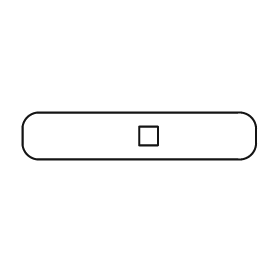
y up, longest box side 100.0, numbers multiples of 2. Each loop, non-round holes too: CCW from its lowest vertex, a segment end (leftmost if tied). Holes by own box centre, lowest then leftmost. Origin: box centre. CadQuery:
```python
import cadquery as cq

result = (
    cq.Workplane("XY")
    .moveTo(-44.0, -10.0)
    .lineTo(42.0, -10.0)
    .threePointArc((48.0, -8.0), (50.0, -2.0))
    .lineTo(50.0, 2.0)
    .threePointArc((48.0, 8.0), (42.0, 10.0))
    .lineTo(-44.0, 10.0)
    .threePointArc((-48.0, 8.0), (-50.0, 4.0))
    .lineTo(-50.0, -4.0)
    .threePointArc((-48.0, -8.0), (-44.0, -10.0))
    .close()
    .moveTo(0.0, -4.0)
    .lineTo(8.0, -4.0)
    .lineTo(8.0, 4.0)
    .lineTo(0.0, 4.0)
    .close()
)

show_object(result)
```